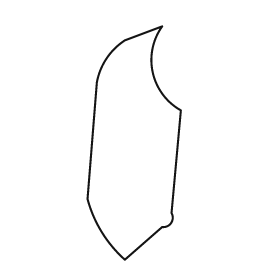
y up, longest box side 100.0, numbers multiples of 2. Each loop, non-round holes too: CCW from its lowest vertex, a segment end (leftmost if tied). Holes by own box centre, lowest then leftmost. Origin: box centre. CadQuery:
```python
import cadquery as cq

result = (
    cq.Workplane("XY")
    .moveTo(-4.0, -50.0)
    .lineTo(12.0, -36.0)
    .threePointArc((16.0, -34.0), (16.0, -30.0))
    .lineTo(20.0, 14.0)
    .threePointArc((8.0, 30.0), (12.0, 50.0))
    .lineTo(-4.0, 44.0)
    .threePointArc((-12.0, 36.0), (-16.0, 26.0))
    .lineTo(-20.0, -24.0)
    .threePointArc((-14.0, -38.0), (-4.0, -50.0))
    .close()
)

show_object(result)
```